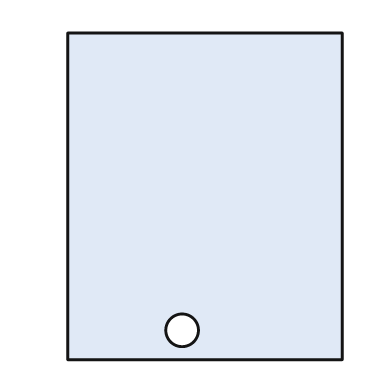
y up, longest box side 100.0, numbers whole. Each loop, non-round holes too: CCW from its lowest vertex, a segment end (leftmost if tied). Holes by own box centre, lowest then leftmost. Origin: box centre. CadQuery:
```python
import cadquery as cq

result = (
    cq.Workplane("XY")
    .moveTo(-42.0, -50.0)
    .lineTo(42.0, -50.0)
    .lineTo(42.0, 50.0)
    .lineTo(-42.0, 50.0)
    .close()
    .moveTo(-7.0, -41.0)
    .circle(5.0)
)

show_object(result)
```